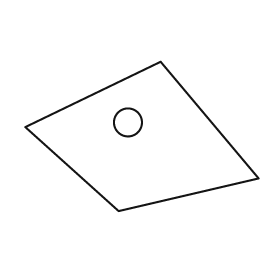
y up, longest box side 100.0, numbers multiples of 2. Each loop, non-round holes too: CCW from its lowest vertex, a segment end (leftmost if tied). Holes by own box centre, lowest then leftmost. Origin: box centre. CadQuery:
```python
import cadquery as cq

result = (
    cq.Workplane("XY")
    .moveTo(-10.0, -32.0)
    .lineTo(50.0, -18.0)
    .lineTo(8.0, 32.0)
    .lineTo(-50.0, 4.0)
    .close()
    .moveTo(-6.0, 6.0)
    .circle(6.0)
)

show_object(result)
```